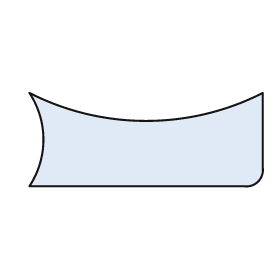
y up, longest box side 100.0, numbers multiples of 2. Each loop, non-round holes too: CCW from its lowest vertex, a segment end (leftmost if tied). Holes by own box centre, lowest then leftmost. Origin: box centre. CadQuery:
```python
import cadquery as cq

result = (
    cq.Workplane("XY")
    .moveTo(-50.0, -20.0)
    .lineTo(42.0, -20.0)
    .threePointArc((48.0, -18.0), (50.0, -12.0))
    .lineTo(50.0, 20.0)
    .threePointArc((0.0, 8.0), (-50.0, 20.0))
    .threePointArc((-44.0, 0.0), (-50.0, -20.0))
    .close()
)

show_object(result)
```